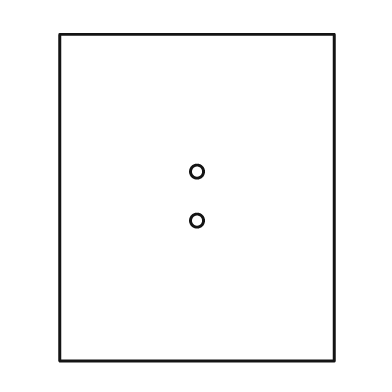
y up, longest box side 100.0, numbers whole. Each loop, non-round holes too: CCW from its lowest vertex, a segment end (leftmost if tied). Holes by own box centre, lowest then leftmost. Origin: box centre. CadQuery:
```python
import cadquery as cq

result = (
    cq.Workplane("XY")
    .moveTo(-42.0, -50.0)
    .lineTo(42.0, -50.0)
    .lineTo(42.0, 50.0)
    .lineTo(-42.0, 50.0)
    .close()
    .moveTo(0.0, -7.0)
    .circle(2.0)
    .moveTo(0.0, 8.0)
    .circle(2.0)
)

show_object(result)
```